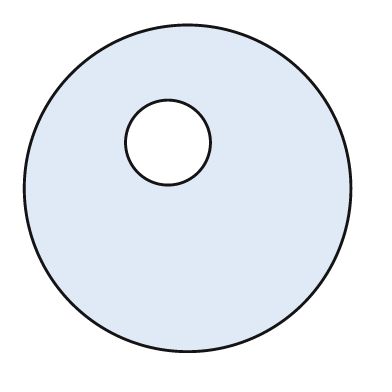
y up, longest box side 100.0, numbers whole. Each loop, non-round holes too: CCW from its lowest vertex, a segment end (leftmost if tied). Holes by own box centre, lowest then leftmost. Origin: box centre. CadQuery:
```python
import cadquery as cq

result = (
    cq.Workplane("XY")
    .moveTo(0.0, 0.0)
    .circle(50.0)
    .moveTo(-6.0, 14.0)
    .circle(13.0)
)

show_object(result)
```